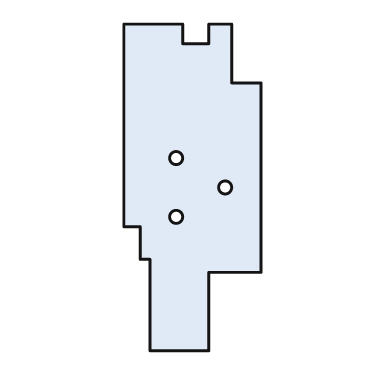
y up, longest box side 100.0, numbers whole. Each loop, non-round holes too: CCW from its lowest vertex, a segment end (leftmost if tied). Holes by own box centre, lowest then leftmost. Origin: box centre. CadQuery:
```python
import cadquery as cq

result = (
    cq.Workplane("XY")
    .moveTo(-13.0, -50.0)
    .lineTo(5.0, -50.0)
    .lineTo(5.0, -26.0)
    .lineTo(21.0, -26.0)
    .lineTo(21.0, 32.0)
    .lineTo(12.0, 32.0)
    .lineTo(12.0, 50.0)
    .lineTo(5.0, 50.0)
    .lineTo(5.0, 44.0)
    .lineTo(-3.0, 44.0)
    .lineTo(-3.0, 50.0)
    .lineTo(-21.0, 50.0)
    .lineTo(-21.0, -12.0)
    .lineTo(-16.0, -12.0)
    .lineTo(-16.0, -22.0)
    .lineTo(-13.0, -22.0)
    .close()
    .moveTo(-5.0, -9.0)
    .circle(2.0)
    .moveTo(10.0, 0.0)
    .circle(2.0)
    .moveTo(-5.0, 9.0)
    .circle(2.0)
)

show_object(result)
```